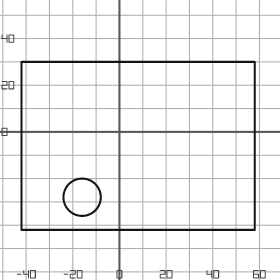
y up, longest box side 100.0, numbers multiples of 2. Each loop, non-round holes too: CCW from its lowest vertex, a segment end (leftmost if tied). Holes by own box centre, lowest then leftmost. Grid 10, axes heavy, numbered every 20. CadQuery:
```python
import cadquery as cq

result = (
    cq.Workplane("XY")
    .moveTo(-42.0, -42.0)
    .lineTo(58.0, -42.0)
    .lineTo(58.0, 30.0)
    .lineTo(-42.0, 30.0)
    .close()
    .moveTo(-16.0, -28.0)
    .circle(8.0)
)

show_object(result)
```